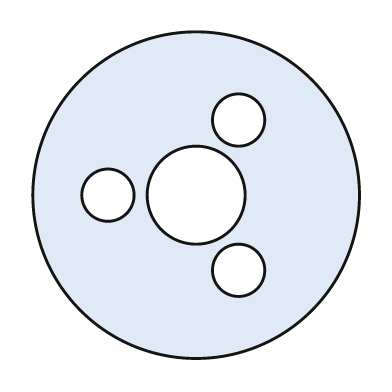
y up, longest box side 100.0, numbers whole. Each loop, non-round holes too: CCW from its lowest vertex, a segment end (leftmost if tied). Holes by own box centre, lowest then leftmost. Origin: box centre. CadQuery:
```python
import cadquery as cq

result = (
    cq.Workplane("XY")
    .moveTo(0.0, 0.0)
    .circle(50.0)
    .moveTo(13.0, -23.0)
    .circle(8.0)
    .moveTo(-27.0, 0.0)
    .circle(8.0)
    .moveTo(0.0, 0.0)
    .circle(15.0)
    .moveTo(13.0, 23.0)
    .circle(8.0)
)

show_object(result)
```